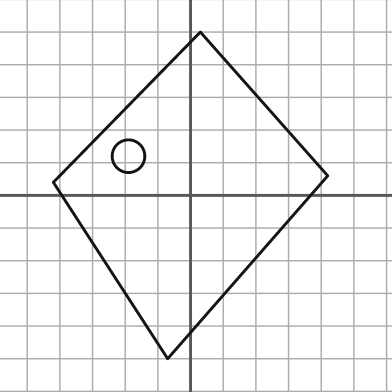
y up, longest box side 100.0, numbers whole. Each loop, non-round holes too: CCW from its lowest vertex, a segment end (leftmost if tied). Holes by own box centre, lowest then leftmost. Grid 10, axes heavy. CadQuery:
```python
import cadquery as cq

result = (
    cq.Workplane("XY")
    .moveTo(-7.0, -50.0)
    .lineTo(42.0, 6.0)
    .lineTo(3.0, 50.0)
    .lineTo(-42.0, 4.0)
    .close()
    .moveTo(-19.0, 12.0)
    .circle(5.0)
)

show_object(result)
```